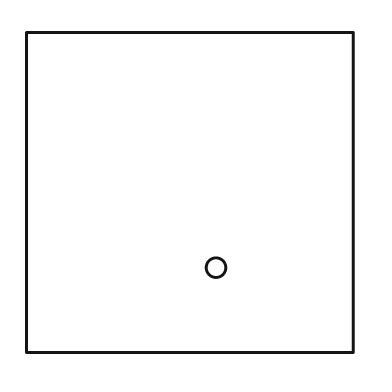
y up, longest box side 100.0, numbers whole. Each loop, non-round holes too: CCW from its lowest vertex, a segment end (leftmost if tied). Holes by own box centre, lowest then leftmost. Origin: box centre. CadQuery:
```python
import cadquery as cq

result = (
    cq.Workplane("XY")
    .moveTo(-50.0, -49.0)
    .lineTo(50.0, -49.0)
    .lineTo(50.0, 49.0)
    .lineTo(-50.0, 49.0)
    .close()
    .moveTo(8.0, -23.0)
    .circle(3.0)
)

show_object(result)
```